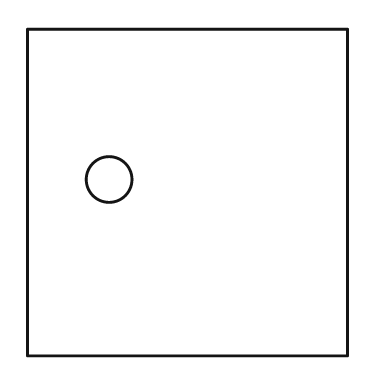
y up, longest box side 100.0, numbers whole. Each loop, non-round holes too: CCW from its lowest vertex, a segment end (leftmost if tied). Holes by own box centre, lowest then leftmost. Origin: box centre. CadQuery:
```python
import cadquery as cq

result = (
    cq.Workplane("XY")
    .moveTo(-49.0, -50.0)
    .lineTo(49.0, -50.0)
    .lineTo(49.0, 50.0)
    .lineTo(-49.0, 50.0)
    .close()
    .moveTo(-24.0, 4.0)
    .circle(7.0)
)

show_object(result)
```